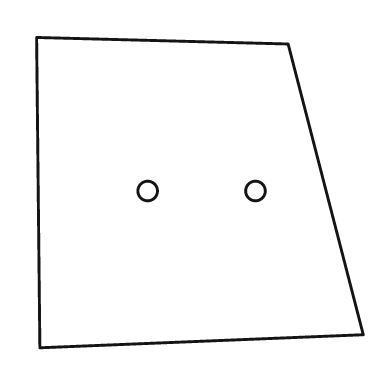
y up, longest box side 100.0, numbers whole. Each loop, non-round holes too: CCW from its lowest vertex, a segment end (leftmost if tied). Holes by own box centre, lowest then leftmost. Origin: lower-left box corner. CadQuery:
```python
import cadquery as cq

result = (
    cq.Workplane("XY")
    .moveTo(1.0, 0.0)
    .lineTo(100.0, 4.0)
    .lineTo(77.0, 93.0)
    .lineTo(0.0, 95.0)
    .close()
    .moveTo(34.0, 48.0)
    .circle(3.0)
    .moveTo(67.0, 48.0)
    .circle(3.0)
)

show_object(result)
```